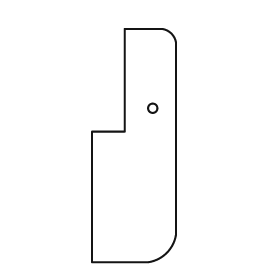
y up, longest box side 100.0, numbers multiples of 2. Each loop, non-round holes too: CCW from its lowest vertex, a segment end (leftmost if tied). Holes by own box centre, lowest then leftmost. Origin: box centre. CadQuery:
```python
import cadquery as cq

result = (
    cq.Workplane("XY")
    .moveTo(-18.0, -50.0)
    .lineTo(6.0, -50.0)
    .threePointArc((14.0, -46.0), (18.0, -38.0))
    .lineTo(18.0, 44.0)
    .threePointArc((16.0, 48.0), (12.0, 50.0))
    .lineTo(-4.0, 50.0)
    .lineTo(-4.0, 6.0)
    .lineTo(-18.0, 6.0)
    .close()
    .moveTo(8.0, 16.0)
    .circle(2.0)
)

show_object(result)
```